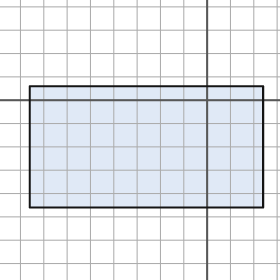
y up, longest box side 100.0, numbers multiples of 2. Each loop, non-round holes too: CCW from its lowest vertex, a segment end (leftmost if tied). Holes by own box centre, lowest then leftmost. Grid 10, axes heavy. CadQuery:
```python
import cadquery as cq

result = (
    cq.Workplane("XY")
    .moveTo(-76.0, -46.0)
    .lineTo(24.0, -46.0)
    .lineTo(24.0, 6.0)
    .lineTo(-76.0, 6.0)
    .close()
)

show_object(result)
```